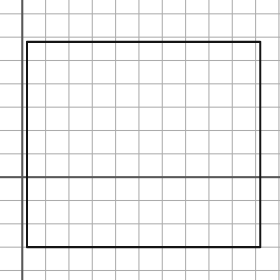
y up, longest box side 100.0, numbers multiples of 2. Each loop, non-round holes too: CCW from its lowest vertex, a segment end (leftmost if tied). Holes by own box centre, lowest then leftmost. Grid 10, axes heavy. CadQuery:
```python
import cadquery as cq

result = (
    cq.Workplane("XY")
    .moveTo(2.0, -30.0)
    .lineTo(102.0, -30.0)
    .lineTo(102.0, 58.0)
    .lineTo(2.0, 58.0)
    .close()
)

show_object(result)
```